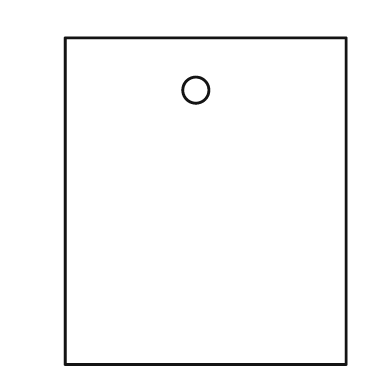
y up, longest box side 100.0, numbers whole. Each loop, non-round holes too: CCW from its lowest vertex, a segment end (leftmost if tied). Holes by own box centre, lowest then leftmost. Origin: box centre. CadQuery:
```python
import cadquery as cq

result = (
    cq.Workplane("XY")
    .moveTo(-43.0, -50.0)
    .lineTo(43.0, -50.0)
    .lineTo(43.0, 50.0)
    .lineTo(-43.0, 50.0)
    .close()
    .moveTo(-3.0, 34.0)
    .circle(4.0)
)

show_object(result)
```